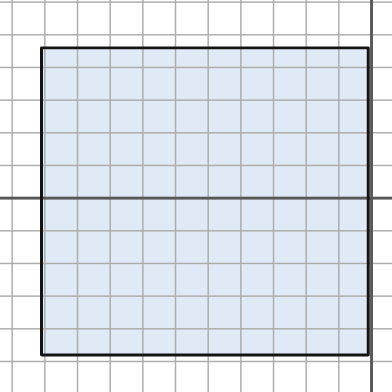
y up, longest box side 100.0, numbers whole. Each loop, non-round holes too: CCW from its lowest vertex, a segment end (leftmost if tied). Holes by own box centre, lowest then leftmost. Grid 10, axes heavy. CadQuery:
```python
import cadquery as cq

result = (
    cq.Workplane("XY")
    .moveTo(-101.0, -48.0)
    .lineTo(-1.0, -48.0)
    .lineTo(-1.0, 46.0)
    .lineTo(-101.0, 46.0)
    .close()
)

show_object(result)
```